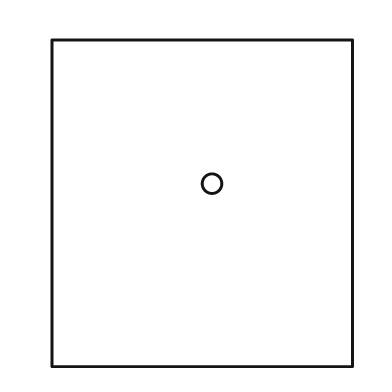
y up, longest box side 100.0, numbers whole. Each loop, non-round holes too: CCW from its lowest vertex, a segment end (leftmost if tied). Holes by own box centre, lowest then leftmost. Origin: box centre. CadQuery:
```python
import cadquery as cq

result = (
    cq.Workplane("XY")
    .moveTo(-46.0, -50.0)
    .lineTo(46.0, -50.0)
    .lineTo(46.0, 50.0)
    .lineTo(-46.0, 50.0)
    .close()
    .moveTo(3.0, 6.0)
    .circle(3.0)
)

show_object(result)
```